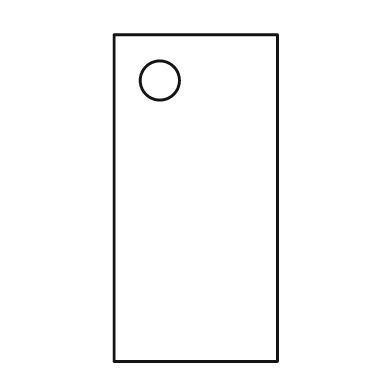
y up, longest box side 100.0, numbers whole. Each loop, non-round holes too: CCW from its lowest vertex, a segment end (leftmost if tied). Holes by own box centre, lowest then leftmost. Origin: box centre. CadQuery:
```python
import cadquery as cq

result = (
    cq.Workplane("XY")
    .moveTo(-25.0, -50.0)
    .lineTo(25.0, -50.0)
    .lineTo(25.0, 50.0)
    .lineTo(-25.0, 50.0)
    .close()
    .moveTo(-11.0, 36.0)
    .circle(6.0)
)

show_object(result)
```